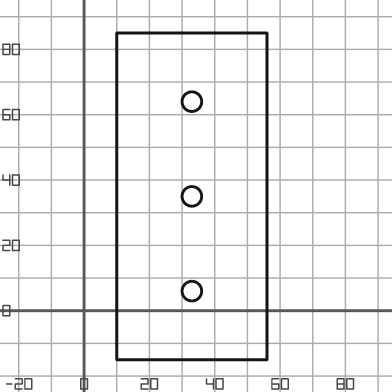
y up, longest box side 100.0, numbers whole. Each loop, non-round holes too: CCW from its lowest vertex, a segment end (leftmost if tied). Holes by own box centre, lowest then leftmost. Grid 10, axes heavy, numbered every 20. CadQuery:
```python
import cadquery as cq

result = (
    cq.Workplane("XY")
    .moveTo(10.0, -15.0)
    .lineTo(56.0, -15.0)
    .lineTo(56.0, 85.0)
    .lineTo(10.0, 85.0)
    .close()
    .moveTo(33.0, 6.0)
    .circle(3.0)
    .moveTo(33.0, 35.0)
    .circle(3.0)
    .moveTo(33.0, 64.0)
    .circle(3.0)
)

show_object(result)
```